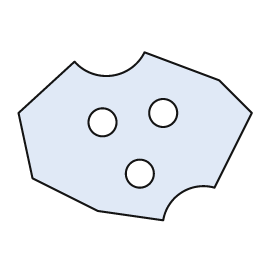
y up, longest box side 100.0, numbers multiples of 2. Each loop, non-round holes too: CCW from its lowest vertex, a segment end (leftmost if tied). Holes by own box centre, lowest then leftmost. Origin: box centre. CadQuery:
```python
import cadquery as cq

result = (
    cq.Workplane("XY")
    .moveTo(12.0, -36.0)
    .threePointArc((20.0, -24.0), (34.0, -22.0))
    .lineTo(50.0, 10.0)
    .lineTo(36.0, 24.0)
    .lineTo(4.0, 36.0)
    .threePointArc((-10.0, 26.0), (-26.0, 32.0))
    .lineTo(-50.0, 10.0)
    .lineTo(-44.0, -18.0)
    .lineTo(-16.0, -32.0)
    .close()
    .moveTo(2.0, -16.0)
    .circle(6.0)
    .moveTo(-14.0, 6.0)
    .circle(6.0)
    .moveTo(12.0, 10.0)
    .circle(6.0)
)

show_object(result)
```